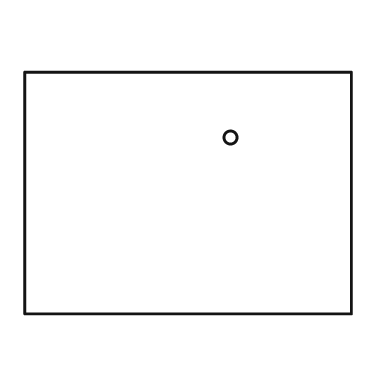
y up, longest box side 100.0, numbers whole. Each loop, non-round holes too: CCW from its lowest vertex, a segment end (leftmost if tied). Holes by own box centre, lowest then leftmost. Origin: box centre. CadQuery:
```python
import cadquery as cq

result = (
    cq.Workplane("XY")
    .moveTo(-50.0, -37.0)
    .lineTo(50.0, -37.0)
    .lineTo(50.0, 37.0)
    .lineTo(-50.0, 37.0)
    .close()
    .moveTo(13.0, 17.0)
    .circle(2.0)
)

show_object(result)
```